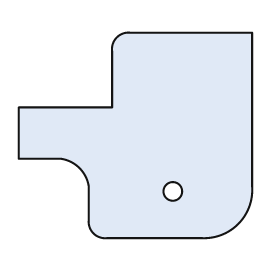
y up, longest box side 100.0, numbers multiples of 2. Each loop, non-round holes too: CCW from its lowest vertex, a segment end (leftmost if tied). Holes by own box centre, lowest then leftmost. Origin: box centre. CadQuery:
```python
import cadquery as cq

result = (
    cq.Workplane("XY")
    .moveTo(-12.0, -44.0)
    .lineTo(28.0, -44.0)
    .threePointArc((44.0, -38.0), (50.0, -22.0))
    .lineTo(50.0, 44.0)
    .lineTo(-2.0, 44.0)
    .threePointArc((-8.0, 42.0), (-10.0, 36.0))
    .lineTo(-10.0, 12.0)
    .lineTo(-50.0, 12.0)
    .lineTo(-50.0, -10.0)
    .lineTo(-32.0, -10.0)
    .threePointArc((-24.0, -14.0), (-20.0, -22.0))
    .lineTo(-20.0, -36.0)
    .threePointArc((-18.0, -42.0), (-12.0, -44.0))
    .close()
    .moveTo(16.0, -24.0)
    .circle(4.0)
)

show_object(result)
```